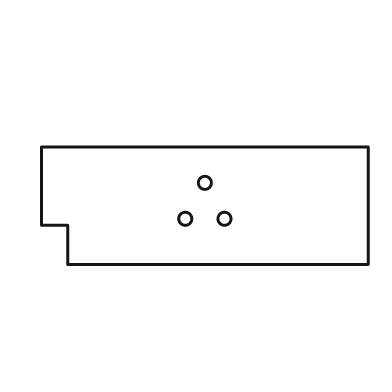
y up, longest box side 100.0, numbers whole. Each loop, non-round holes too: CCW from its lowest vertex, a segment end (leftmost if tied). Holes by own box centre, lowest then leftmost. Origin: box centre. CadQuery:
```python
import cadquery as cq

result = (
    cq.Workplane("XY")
    .moveTo(-42.0, -18.0)
    .lineTo(50.0, -18.0)
    .lineTo(50.0, 18.0)
    .lineTo(-50.0, 18.0)
    .lineTo(-50.0, -6.0)
    .lineTo(-42.0, -6.0)
    .close()
    .moveTo(-6.0, -4.0)
    .circle(2.0)
    .moveTo(6.0, -4.0)
    .circle(2.0)
    .moveTo(0.0, 7.0)
    .circle(2.0)
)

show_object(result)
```